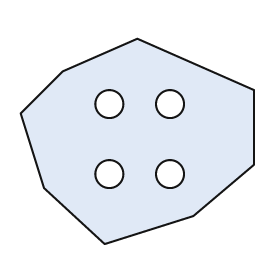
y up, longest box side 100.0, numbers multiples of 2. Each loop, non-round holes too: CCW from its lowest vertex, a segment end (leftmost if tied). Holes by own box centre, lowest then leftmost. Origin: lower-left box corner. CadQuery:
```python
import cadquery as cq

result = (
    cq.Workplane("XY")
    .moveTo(36.0, 0.0)
    .lineTo(74.0, 12.0)
    .lineTo(100.0, 34.0)
    .lineTo(100.0, 66.0)
    .lineTo(50.0, 88.0)
    .lineTo(18.0, 74.0)
    .lineTo(0.0, 56.0)
    .lineTo(10.0, 24.0)
    .close()
    .moveTo(38.0, 30.0)
    .circle(6.0)
    .moveTo(64.0, 30.0)
    .circle(6.0)
    .moveTo(38.0, 60.0)
    .circle(6.0)
    .moveTo(64.0, 60.0)
    .circle(6.0)
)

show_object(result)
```